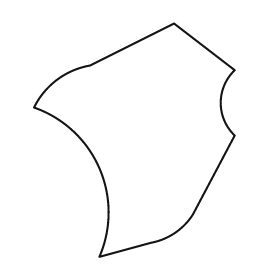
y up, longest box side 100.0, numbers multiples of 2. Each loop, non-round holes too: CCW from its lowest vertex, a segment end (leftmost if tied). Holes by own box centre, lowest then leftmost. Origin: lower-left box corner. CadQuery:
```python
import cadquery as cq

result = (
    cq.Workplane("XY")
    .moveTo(28.0, 0.0)
    .lineTo(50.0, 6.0)
    .threePointArc((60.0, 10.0), (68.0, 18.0))
    .lineTo(86.0, 52.0)
    .threePointArc((80.0, 66.0), (86.0, 80.0))
    .lineTo(60.0, 100.0)
    .lineTo(24.0, 82.0)
    .threePointArc((10.0, 76.0), (0.0, 64.0))
    .threePointArc((28.0, 38.0), (28.0, 0.0))
    .close()
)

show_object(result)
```